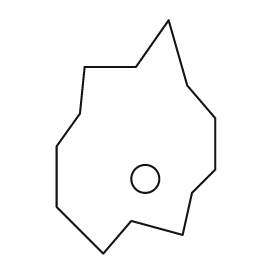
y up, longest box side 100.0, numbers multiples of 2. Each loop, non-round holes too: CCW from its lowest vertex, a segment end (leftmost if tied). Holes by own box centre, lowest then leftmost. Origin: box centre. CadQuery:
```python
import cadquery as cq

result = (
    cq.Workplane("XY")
    .moveTo(-14.0, -50.0)
    .lineTo(-2.0, -36.0)
    .lineTo(20.0, -42.0)
    .lineTo(24.0, -24.0)
    .lineTo(34.0, -14.0)
    .lineTo(34.0, 8.0)
    .lineTo(22.0, 22.0)
    .lineTo(14.0, 50.0)
    .lineTo(0.0, 30.0)
    .lineTo(-22.0, 30.0)
    .lineTo(-24.0, 10.0)
    .lineTo(-34.0, -4.0)
    .lineTo(-34.0, -30.0)
    .close()
    .moveTo(4.0, -18.0)
    .circle(6.0)
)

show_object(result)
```